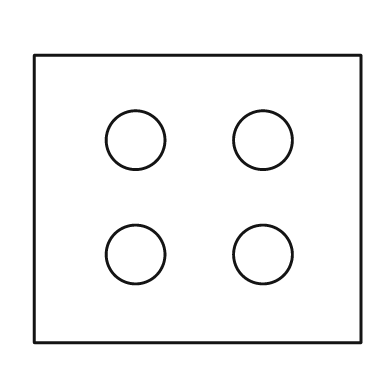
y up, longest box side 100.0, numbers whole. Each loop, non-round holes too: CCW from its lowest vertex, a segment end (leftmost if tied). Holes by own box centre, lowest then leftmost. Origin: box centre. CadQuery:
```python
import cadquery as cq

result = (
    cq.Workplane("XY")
    .moveTo(-50.0, -44.0)
    .lineTo(50.0, -44.0)
    .lineTo(50.0, 44.0)
    .lineTo(-50.0, 44.0)
    .close()
    .moveTo(-19.0, -17.0)
    .circle(9.0)
    .moveTo(20.0, -17.0)
    .circle(9.0)
    .moveTo(-19.0, 18.0)
    .circle(9.0)
    .moveTo(20.0, 18.0)
    .circle(9.0)
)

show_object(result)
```